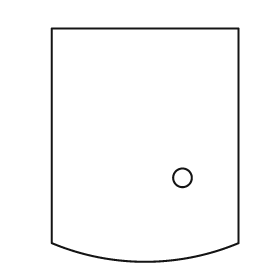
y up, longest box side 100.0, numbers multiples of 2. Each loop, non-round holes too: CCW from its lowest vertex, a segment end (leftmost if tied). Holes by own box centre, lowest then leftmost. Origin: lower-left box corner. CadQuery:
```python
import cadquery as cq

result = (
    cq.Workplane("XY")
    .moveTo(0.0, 8.0)
    .threePointArc((40.0, 0.0), (80.0, 8.0))
    .lineTo(80.0, 100.0)
    .lineTo(0.0, 100.0)
    .close()
    .moveTo(56.0, 36.0)
    .circle(4.0)
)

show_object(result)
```